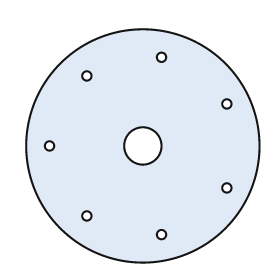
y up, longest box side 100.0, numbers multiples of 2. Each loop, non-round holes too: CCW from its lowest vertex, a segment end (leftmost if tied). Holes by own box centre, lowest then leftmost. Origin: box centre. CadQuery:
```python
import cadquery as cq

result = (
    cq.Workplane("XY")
    .moveTo(0.0, 0.0)
    .circle(50.0)
    .moveTo(8.0, -38.0)
    .circle(2.0)
    .moveTo(-24.0, -30.0)
    .circle(2.0)
    .moveTo(36.0, -18.0)
    .circle(2.0)
    .moveTo(-40.0, 0.0)
    .circle(2.0)
    .moveTo(0.0, 0.0)
    .circle(8.0)
    .moveTo(36.0, 18.0)
    .circle(2.0)
    .moveTo(-24.0, 30.0)
    .circle(2.0)
    .moveTo(8.0, 38.0)
    .circle(2.0)
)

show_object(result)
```